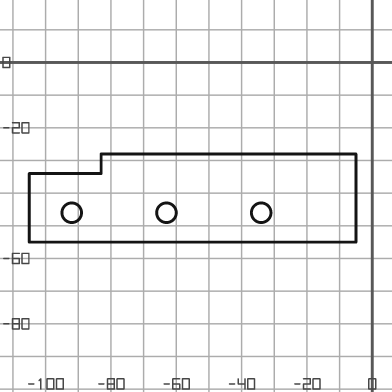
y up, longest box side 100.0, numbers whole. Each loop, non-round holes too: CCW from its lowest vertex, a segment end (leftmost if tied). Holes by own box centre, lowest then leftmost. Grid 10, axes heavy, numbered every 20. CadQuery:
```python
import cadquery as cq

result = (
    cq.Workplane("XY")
    .moveTo(-105.0, -55.0)
    .lineTo(-5.0, -55.0)
    .lineTo(-5.0, -28.0)
    .lineTo(-83.0, -28.0)
    .lineTo(-83.0, -34.0)
    .lineTo(-105.0, -34.0)
    .close()
    .moveTo(-92.0, -46.0)
    .circle(3.0)
    .moveTo(-63.0, -46.0)
    .circle(3.0)
    .moveTo(-34.0, -46.0)
    .circle(3.0)
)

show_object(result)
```